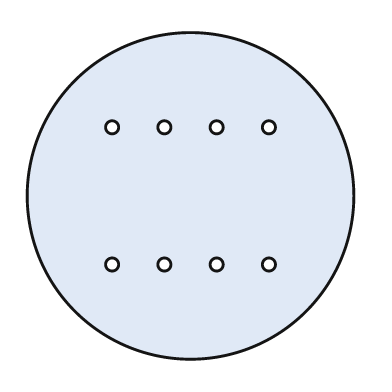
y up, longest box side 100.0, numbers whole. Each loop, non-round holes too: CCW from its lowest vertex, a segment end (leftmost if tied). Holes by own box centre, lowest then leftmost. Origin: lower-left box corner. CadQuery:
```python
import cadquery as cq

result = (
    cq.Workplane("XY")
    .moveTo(50.0, 50.0)
    .circle(50.0)
    .moveTo(26.0, 29.0)
    .circle(2.0)
    .moveTo(42.0, 29.0)
    .circle(2.0)
    .moveTo(58.0, 29.0)
    .circle(2.0)
    .moveTo(74.0, 29.0)
    .circle(2.0)
    .moveTo(26.0, 71.0)
    .circle(2.0)
    .moveTo(42.0, 71.0)
    .circle(2.0)
    .moveTo(58.0, 71.0)
    .circle(2.0)
    .moveTo(74.0, 71.0)
    .circle(2.0)
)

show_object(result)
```